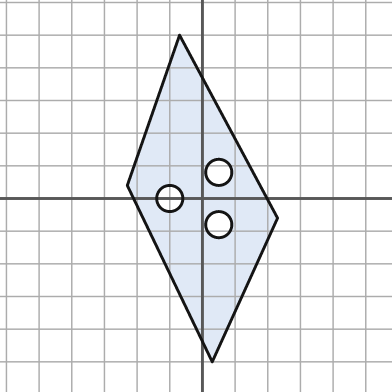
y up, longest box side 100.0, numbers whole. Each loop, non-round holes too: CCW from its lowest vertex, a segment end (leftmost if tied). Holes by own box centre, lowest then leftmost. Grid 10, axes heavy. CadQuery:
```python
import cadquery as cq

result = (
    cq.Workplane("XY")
    .moveTo(3.0, -50.0)
    .lineTo(23.0, -6.0)
    .lineTo(-7.0, 50.0)
    .lineTo(-23.0, 4.0)
    .close()
    .moveTo(5.0, -8.0)
    .circle(4.0)
    .moveTo(-10.0, 0.0)
    .circle(4.0)
    .moveTo(5.0, 8.0)
    .circle(4.0)
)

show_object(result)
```